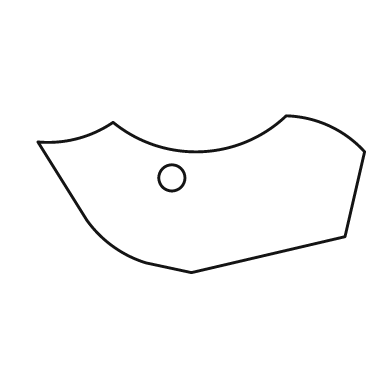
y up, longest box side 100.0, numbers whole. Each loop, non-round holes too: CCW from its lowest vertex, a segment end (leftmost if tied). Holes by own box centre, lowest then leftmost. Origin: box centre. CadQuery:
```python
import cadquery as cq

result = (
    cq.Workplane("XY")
    .moveTo(-3.0, -24.0)
    .lineTo(44.0, -13.0)
    .lineTo(50.0, 13.0)
    .threePointArc((39.0, 21.0), (26.0, 24.0))
    .threePointArc((0.0, 13.0), (-27.0, 22.0))
    .threePointArc((-38.0, 17.0), (-50.0, 16.0))
    .lineTo(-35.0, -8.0)
    .threePointArc((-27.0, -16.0), (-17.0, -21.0))
    .close()
    .moveTo(-9.0, 5.0)
    .circle(4.0)
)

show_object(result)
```